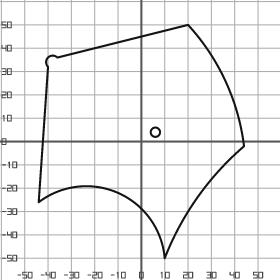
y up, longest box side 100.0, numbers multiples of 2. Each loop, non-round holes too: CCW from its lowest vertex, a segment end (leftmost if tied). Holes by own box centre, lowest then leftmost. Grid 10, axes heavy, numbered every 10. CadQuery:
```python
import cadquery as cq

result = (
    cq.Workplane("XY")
    .moveTo(10.0, -50.0)
    .threePointArc((24.0, -24.0), (44.0, -2.0))
    .threePointArc((36.0, 26.0), (20.0, 50.0))
    .lineTo(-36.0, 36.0)
    .threePointArc((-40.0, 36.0), (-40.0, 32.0))
    .lineTo(-44.0, -26.0)
    .threePointArc((-10.0, -22.0), (10.0, -50.0))
    .close()
    .moveTo(6.0, 4.0)
    .circle(2.0)
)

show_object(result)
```